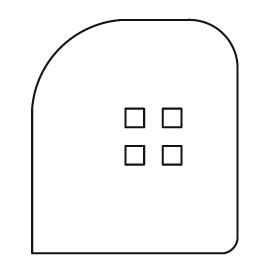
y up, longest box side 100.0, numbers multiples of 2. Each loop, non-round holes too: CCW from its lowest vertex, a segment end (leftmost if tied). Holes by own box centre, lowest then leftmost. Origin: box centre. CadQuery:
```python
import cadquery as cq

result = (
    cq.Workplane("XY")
    .moveTo(-44.0, -50.0)
    .lineTo(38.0, -50.0)
    .threePointArc((42.0, -48.0), (44.0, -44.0))
    .lineTo(44.0, 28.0)
    .threePointArc((38.0, 44.0), (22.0, 50.0))
    .lineTo(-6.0, 50.0)
    .threePointArc((-32.0, 38.0), (-44.0, 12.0))
    .close()
    .moveTo(-4.0, -12.0)
    .lineTo(4.0, -12.0)
    .lineTo(4.0, -4.0)
    .lineTo(-4.0, -4.0)
    .close()
    .moveTo(12.0, -12.0)
    .lineTo(20.0, -12.0)
    .lineTo(20.0, -4.0)
    .lineTo(12.0, -4.0)
    .close()
    .moveTo(-4.0, 4.0)
    .lineTo(4.0, 4.0)
    .lineTo(4.0, 12.0)
    .lineTo(-4.0, 12.0)
    .close()
    .moveTo(12.0, 4.0)
    .lineTo(20.0, 4.0)
    .lineTo(20.0, 12.0)
    .lineTo(12.0, 12.0)
    .close()
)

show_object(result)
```